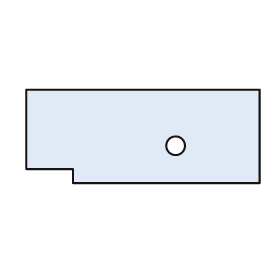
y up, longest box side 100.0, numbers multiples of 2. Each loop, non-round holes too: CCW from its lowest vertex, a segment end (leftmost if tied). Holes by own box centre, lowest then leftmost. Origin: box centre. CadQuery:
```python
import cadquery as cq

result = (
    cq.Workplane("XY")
    .moveTo(-30.0, -20.0)
    .lineTo(50.0, -20.0)
    .lineTo(50.0, 20.0)
    .lineTo(-50.0, 20.0)
    .lineTo(-50.0, -14.0)
    .lineTo(-30.0, -14.0)
    .close()
    .moveTo(14.0, -4.0)
    .circle(4.0)
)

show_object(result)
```